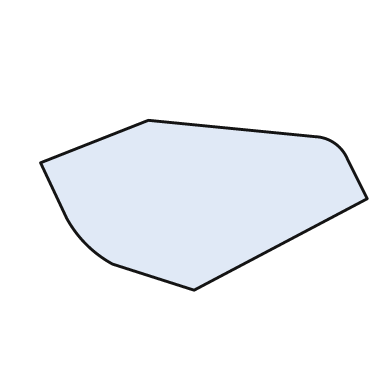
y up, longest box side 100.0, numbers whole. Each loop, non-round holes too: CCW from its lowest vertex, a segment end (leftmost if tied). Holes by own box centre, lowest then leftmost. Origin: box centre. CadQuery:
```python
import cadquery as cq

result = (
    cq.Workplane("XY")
    .moveTo(-3.0, -26.0)
    .lineTo(50.0, 2.0)
    .lineTo(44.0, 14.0)
    .threePointArc((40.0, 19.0), (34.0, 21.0))
    .lineTo(-17.0, 26.0)
    .lineTo(-50.0, 13.0)
    .lineTo(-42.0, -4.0)
    .threePointArc((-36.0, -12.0), (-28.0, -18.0))
    .close()
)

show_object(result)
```